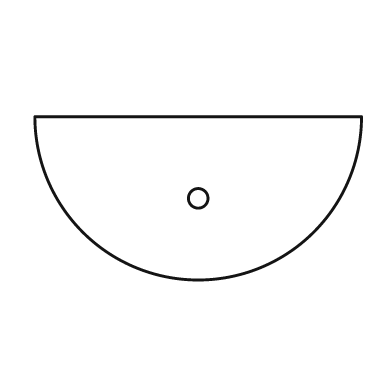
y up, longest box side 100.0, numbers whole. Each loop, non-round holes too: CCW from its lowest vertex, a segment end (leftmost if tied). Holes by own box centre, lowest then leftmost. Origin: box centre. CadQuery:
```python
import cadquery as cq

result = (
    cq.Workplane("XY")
    .moveTo(-50.0, 25.0)
    .threePointArc((0.0, -25.0), (50.0, 25.0))
    .close()
    .moveTo(0.0, 0.0)
    .circle(3.0)
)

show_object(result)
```